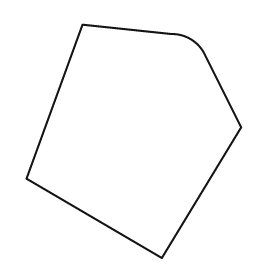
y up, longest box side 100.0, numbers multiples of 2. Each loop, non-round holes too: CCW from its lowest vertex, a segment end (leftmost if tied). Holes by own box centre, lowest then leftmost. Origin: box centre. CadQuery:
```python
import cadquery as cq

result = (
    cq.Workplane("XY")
    .moveTo(12.0, -50.0)
    .lineTo(46.0, 6.0)
    .lineTo(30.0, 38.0)
    .threePointArc((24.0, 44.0), (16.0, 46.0))
    .lineTo(-22.0, 50.0)
    .lineTo(-46.0, -16.0)
    .close()
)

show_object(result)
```